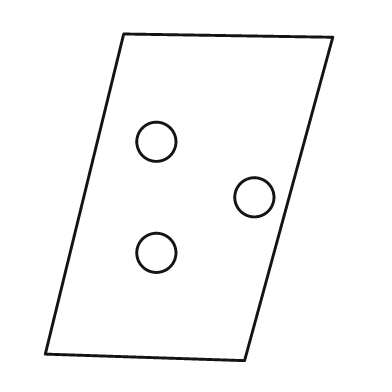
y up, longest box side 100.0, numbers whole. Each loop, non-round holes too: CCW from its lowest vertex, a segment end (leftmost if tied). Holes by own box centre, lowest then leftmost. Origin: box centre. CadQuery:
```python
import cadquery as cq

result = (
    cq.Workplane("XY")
    .moveTo(17.0, -50.0)
    .lineTo(44.0, 49.0)
    .lineTo(-20.0, 50.0)
    .lineTo(-44.0, -48.0)
    .close()
    .moveTo(-10.0, -17.0)
    .circle(6.0)
    .moveTo(20.0, 0.0)
    .circle(6.0)
    .moveTo(-10.0, 17.0)
    .circle(6.0)
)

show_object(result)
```